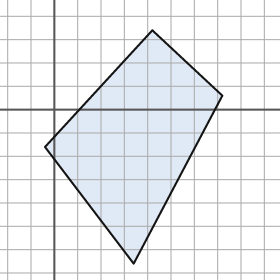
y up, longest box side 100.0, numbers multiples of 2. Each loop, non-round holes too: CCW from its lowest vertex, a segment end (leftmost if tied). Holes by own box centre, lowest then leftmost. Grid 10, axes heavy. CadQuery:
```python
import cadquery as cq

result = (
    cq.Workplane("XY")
    .moveTo(34.0, -66.0)
    .lineTo(72.0, 6.0)
    .lineTo(42.0, 34.0)
    .lineTo(-4.0, -16.0)
    .close()
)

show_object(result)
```